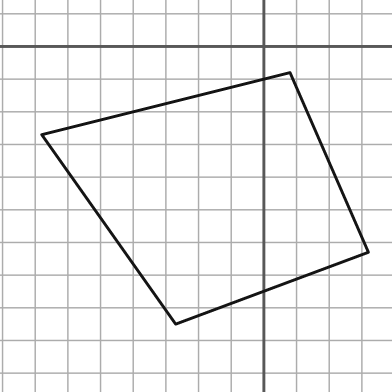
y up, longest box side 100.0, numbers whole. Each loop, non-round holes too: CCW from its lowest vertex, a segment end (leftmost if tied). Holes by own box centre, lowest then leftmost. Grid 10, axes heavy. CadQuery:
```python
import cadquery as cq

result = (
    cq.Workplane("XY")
    .moveTo(-27.0, -85.0)
    .lineTo(32.0, -63.0)
    .lineTo(8.0, -8.0)
    .lineTo(-68.0, -27.0)
    .close()
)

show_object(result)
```